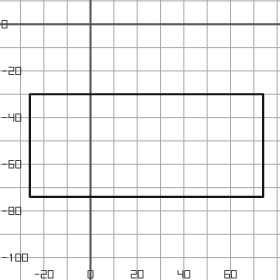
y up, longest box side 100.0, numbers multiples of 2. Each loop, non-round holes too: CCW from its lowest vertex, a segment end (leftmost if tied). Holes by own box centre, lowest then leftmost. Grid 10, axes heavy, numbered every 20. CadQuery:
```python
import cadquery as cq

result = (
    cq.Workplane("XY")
    .moveTo(-26.0, -74.0)
    .lineTo(74.0, -74.0)
    .lineTo(74.0, -30.0)
    .lineTo(-26.0, -30.0)
    .close()
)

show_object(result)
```